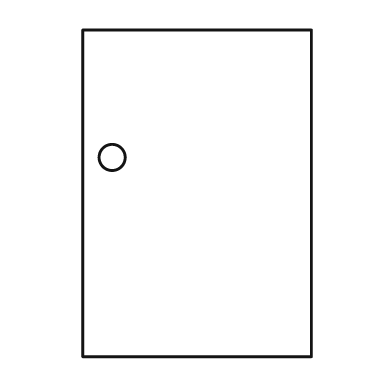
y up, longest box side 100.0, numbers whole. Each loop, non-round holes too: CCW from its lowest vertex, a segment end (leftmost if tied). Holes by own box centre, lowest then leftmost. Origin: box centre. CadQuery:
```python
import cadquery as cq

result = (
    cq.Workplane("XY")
    .moveTo(-35.0, -50.0)
    .lineTo(35.0, -50.0)
    .lineTo(35.0, 50.0)
    .lineTo(-35.0, 50.0)
    .close()
    .moveTo(-26.0, 11.0)
    .circle(4.0)
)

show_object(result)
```